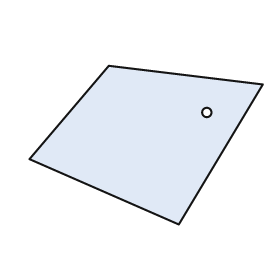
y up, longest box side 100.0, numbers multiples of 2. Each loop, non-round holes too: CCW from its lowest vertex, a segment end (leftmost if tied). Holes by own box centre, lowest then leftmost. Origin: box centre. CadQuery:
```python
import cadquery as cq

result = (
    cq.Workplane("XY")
    .moveTo(14.0, -34.0)
    .lineTo(50.0, 26.0)
    .lineTo(-16.0, 34.0)
    .lineTo(-50.0, -6.0)
    .close()
    .moveTo(26.0, 14.0)
    .circle(2.0)
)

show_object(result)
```